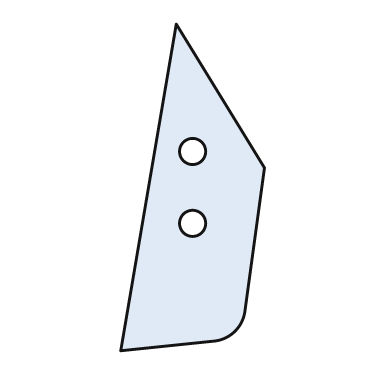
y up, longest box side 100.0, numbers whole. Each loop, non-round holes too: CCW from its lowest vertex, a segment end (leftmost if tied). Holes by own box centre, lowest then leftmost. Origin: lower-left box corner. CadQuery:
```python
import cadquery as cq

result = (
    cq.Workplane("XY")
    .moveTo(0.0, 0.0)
    .lineTo(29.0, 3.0)
    .threePointArc((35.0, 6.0), (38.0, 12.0))
    .lineTo(44.0, 56.0)
    .lineTo(17.0, 100.0)
    .close()
    .moveTo(22.0, 39.0)
    .circle(4.0)
    .moveTo(22.0, 61.0)
    .circle(4.0)
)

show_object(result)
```